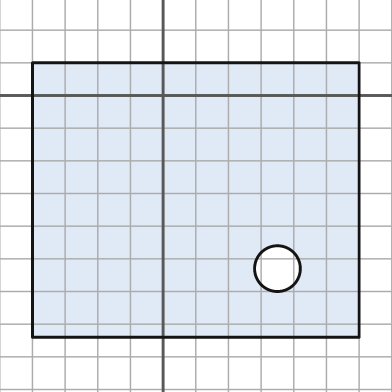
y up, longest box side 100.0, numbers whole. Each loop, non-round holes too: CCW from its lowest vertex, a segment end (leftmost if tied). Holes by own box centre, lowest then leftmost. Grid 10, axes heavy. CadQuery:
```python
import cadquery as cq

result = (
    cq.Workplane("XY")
    .moveTo(-40.0, -74.0)
    .lineTo(60.0, -74.0)
    .lineTo(60.0, 10.0)
    .lineTo(-40.0, 10.0)
    .close()
    .moveTo(35.0, -53.0)
    .circle(7.0)
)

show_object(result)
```